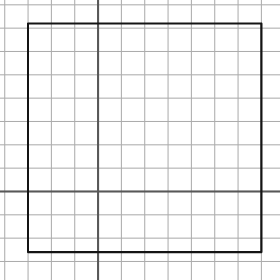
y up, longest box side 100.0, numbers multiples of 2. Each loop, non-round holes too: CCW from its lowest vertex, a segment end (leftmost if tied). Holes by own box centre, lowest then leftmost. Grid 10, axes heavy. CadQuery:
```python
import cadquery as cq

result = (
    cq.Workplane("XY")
    .moveTo(-30.0, -26.0)
    .lineTo(70.0, -26.0)
    .lineTo(70.0, 72.0)
    .lineTo(-30.0, 72.0)
    .close()
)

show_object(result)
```